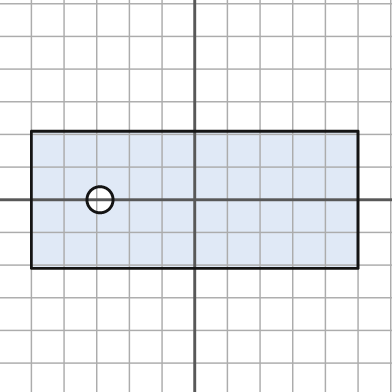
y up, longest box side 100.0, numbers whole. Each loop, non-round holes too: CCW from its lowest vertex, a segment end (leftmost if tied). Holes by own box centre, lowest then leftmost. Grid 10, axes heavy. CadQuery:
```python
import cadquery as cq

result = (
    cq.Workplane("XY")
    .moveTo(-50.0, -21.0)
    .lineTo(50.0, -21.0)
    .lineTo(50.0, 21.0)
    .lineTo(-50.0, 21.0)
    .close()
    .moveTo(-29.0, 0.0)
    .circle(4.0)
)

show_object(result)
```